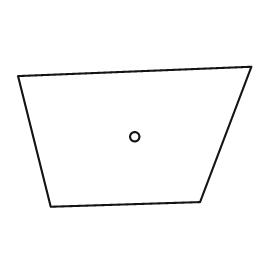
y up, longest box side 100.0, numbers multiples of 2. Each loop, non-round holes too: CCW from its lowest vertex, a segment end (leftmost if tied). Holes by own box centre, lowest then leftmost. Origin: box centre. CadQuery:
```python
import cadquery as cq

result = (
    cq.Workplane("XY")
    .moveTo(-36.0, -30.0)
    .lineTo(28.0, -28.0)
    .lineTo(50.0, 30.0)
    .lineTo(-50.0, 26.0)
    .close()
    .moveTo(0.0, 0.0)
    .circle(2.0)
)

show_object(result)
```